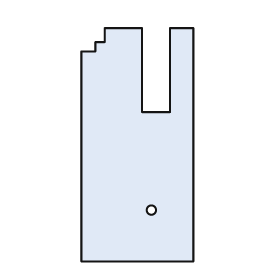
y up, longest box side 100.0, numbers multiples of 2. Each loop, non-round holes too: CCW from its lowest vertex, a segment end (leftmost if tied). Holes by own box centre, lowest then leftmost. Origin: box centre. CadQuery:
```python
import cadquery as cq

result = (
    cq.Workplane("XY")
    .moveTo(-24.0, -50.0)
    .lineTo(24.0, -50.0)
    .lineTo(24.0, 50.0)
    .lineTo(14.0, 50.0)
    .lineTo(14.0, 14.0)
    .lineTo(2.0, 14.0)
    .lineTo(2.0, 50.0)
    .lineTo(-14.0, 50.0)
    .lineTo(-14.0, 44.0)
    .lineTo(-18.0, 44.0)
    .lineTo(-18.0, 40.0)
    .lineTo(-24.0, 40.0)
    .close()
    .moveTo(6.0, -28.0)
    .circle(2.0)
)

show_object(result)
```